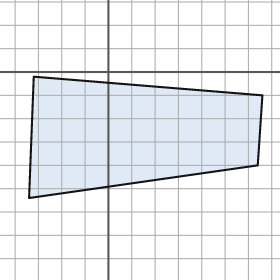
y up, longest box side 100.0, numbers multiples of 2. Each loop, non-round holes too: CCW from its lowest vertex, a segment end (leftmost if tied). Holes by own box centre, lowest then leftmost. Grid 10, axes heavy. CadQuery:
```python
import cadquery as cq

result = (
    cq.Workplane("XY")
    .moveTo(-34.0, -54.0)
    .lineTo(64.0, -40.0)
    .lineTo(66.0, -10.0)
    .lineTo(-32.0, -2.0)
    .close()
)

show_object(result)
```